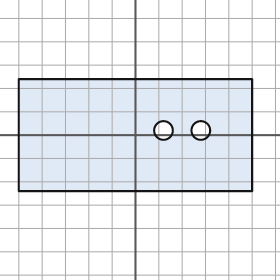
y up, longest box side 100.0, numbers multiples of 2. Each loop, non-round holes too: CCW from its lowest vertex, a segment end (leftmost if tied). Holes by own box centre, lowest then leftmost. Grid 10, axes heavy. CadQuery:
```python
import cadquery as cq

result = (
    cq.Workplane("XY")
    .moveTo(-50.0, -24.0)
    .lineTo(50.0, -24.0)
    .lineTo(50.0, 24.0)
    .lineTo(-50.0, 24.0)
    .close()
    .moveTo(12.0, 2.0)
    .circle(4.0)
    .moveTo(28.0, 2.0)
    .circle(4.0)
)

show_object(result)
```